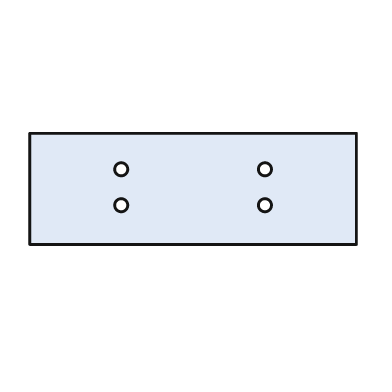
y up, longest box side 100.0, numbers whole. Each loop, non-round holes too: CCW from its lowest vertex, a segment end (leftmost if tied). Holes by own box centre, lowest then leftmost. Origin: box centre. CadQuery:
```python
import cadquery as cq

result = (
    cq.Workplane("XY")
    .moveTo(-50.0, -17.0)
    .lineTo(50.0, -17.0)
    .lineTo(50.0, 17.0)
    .lineTo(-50.0, 17.0)
    .close()
    .moveTo(-22.0, -5.0)
    .circle(2.0)
    .moveTo(22.0, -5.0)
    .circle(2.0)
    .moveTo(-22.0, 6.0)
    .circle(2.0)
    .moveTo(22.0, 6.0)
    .circle(2.0)
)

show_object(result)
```